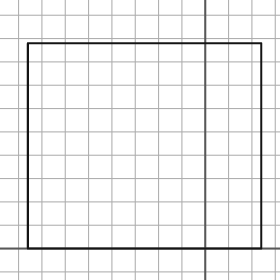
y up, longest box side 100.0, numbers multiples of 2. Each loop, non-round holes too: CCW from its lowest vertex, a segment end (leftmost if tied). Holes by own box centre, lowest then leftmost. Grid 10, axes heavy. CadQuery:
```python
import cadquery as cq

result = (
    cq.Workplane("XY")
    .moveTo(-76.0, 0.0)
    .lineTo(24.0, 0.0)
    .lineTo(24.0, 88.0)
    .lineTo(-76.0, 88.0)
    .close()
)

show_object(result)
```